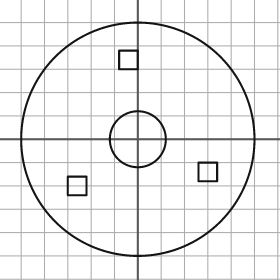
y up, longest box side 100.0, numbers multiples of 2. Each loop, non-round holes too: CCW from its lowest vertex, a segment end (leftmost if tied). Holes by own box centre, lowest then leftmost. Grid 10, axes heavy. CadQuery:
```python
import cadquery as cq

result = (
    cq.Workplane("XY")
    .moveTo(0.0, 0.0)
    .circle(50.0)
    .moveTo(-30.0, -24.0)
    .lineTo(-22.0, -24.0)
    .lineTo(-22.0, -16.0)
    .lineTo(-30.0, -16.0)
    .close()
    .moveTo(26.0, -18.0)
    .lineTo(34.0, -18.0)
    .lineTo(34.0, -10.0)
    .lineTo(26.0, -10.0)
    .close()
    .moveTo(0.0, 0.0)
    .circle(12.0)
    .moveTo(-8.0, 30.0)
    .lineTo(0.0, 30.0)
    .lineTo(0.0, 38.0)
    .lineTo(-8.0, 38.0)
    .close()
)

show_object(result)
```